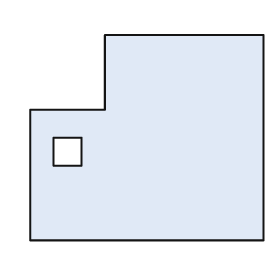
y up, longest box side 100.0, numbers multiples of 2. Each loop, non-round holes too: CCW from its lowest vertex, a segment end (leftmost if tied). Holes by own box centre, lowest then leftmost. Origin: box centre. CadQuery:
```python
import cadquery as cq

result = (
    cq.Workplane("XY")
    .moveTo(-50.0, -44.0)
    .lineTo(50.0, -44.0)
    .lineTo(50.0, 44.0)
    .lineTo(-18.0, 44.0)
    .lineTo(-18.0, 12.0)
    .lineTo(-50.0, 12.0)
    .close()
    .moveTo(-40.0, -12.0)
    .lineTo(-28.0, -12.0)
    .lineTo(-28.0, 0.0)
    .lineTo(-40.0, 0.0)
    .close()
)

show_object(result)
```